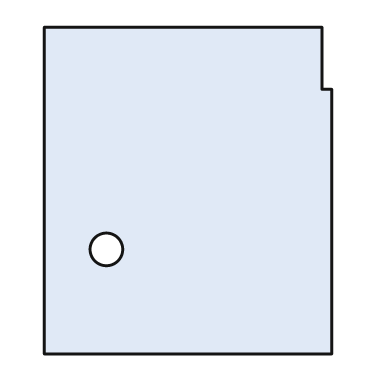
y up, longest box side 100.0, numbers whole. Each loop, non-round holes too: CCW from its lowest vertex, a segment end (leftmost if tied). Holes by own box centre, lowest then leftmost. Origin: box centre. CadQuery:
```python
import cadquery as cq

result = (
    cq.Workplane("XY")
    .moveTo(-44.0, -50.0)
    .lineTo(44.0, -50.0)
    .lineTo(44.0, 31.0)
    .lineTo(41.0, 31.0)
    .lineTo(41.0, 50.0)
    .lineTo(-44.0, 50.0)
    .close()
    .moveTo(-25.0, -18.0)
    .circle(5.0)
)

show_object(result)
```